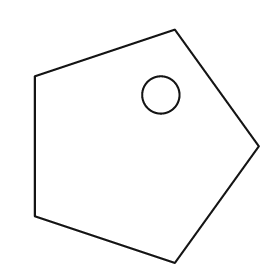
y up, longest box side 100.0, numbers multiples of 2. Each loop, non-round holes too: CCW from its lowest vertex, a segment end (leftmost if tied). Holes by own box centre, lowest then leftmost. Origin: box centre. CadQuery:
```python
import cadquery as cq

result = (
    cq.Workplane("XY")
    .moveTo(12.0, -50.0)
    .lineTo(48.0, 0.0)
    .lineTo(12.0, 50.0)
    .lineTo(-48.0, 30.0)
    .lineTo(-48.0, -30.0)
    .close()
    .moveTo(6.0, 22.0)
    .circle(8.0)
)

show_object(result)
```